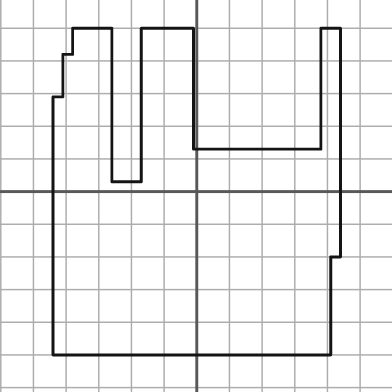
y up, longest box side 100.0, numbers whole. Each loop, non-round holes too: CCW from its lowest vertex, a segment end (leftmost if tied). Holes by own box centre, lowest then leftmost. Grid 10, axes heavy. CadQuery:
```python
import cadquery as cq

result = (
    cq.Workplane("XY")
    .moveTo(-44.0, -50.0)
    .lineTo(41.0, -50.0)
    .lineTo(41.0, -20.0)
    .lineTo(44.0, -20.0)
    .lineTo(44.0, 50.0)
    .lineTo(38.0, 50.0)
    .lineTo(38.0, 13.0)
    .lineTo(-1.0, 13.0)
    .lineTo(-1.0, 50.0)
    .lineTo(-17.0, 50.0)
    .lineTo(-17.0, 3.0)
    .lineTo(-26.0, 3.0)
    .lineTo(-26.0, 50.0)
    .lineTo(-38.0, 50.0)
    .lineTo(-38.0, 42.0)
    .lineTo(-41.0, 42.0)
    .lineTo(-41.0, 29.0)
    .lineTo(-44.0, 29.0)
    .close()
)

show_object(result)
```